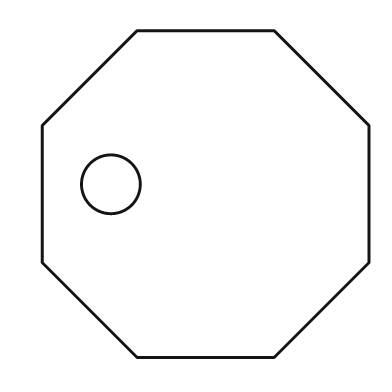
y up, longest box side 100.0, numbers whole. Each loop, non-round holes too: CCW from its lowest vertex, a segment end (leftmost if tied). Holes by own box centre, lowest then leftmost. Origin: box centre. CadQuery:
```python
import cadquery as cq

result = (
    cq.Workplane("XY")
    .moveTo(-21.0, -50.0)
    .lineTo(21.0, -50.0)
    .lineTo(50.0, -21.0)
    .lineTo(50.0, 21.0)
    .lineTo(21.0, 50.0)
    .lineTo(-21.0, 50.0)
    .lineTo(-50.0, 21.0)
    .lineTo(-50.0, -21.0)
    .close()
    .moveTo(-29.0, 3.0)
    .circle(9.0)
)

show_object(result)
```